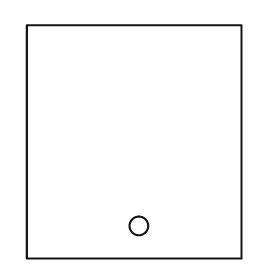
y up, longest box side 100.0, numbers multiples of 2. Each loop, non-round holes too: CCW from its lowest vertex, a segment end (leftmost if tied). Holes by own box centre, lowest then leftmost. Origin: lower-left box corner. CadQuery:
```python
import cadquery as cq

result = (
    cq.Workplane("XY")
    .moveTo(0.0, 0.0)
    .lineTo(92.0, 0.0)
    .lineTo(92.0, 100.0)
    .lineTo(0.0, 100.0)
    .close()
    .moveTo(48.0, 14.0)
    .circle(4.0)
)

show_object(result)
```